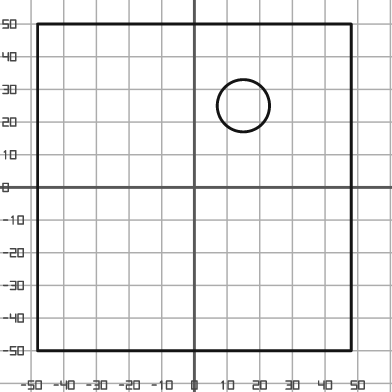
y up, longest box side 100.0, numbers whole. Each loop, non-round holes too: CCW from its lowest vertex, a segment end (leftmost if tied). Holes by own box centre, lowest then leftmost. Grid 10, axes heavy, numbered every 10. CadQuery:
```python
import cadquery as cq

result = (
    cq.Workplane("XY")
    .moveTo(-48.0, -50.0)
    .lineTo(48.0, -50.0)
    .lineTo(48.0, 50.0)
    .lineTo(-48.0, 50.0)
    .close()
    .moveTo(15.0, 25.0)
    .circle(8.0)
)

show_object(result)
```